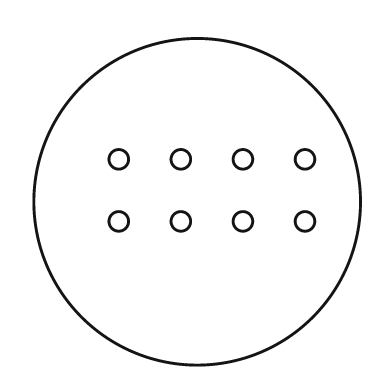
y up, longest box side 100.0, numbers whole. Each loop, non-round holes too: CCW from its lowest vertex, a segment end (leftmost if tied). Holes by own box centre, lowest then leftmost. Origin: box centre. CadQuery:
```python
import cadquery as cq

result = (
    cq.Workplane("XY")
    .moveTo(0.0, 0.0)
    .circle(50.0)
    .moveTo(-24.0, -6.0)
    .circle(3.0)
    .moveTo(-5.0, -6.0)
    .circle(3.0)
    .moveTo(14.0, -6.0)
    .circle(3.0)
    .moveTo(33.0, -6.0)
    .circle(3.0)
    .moveTo(-24.0, 13.0)
    .circle(3.0)
    .moveTo(-5.0, 13.0)
    .circle(3.0)
    .moveTo(14.0, 13.0)
    .circle(3.0)
    .moveTo(33.0, 13.0)
    .circle(3.0)
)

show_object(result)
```